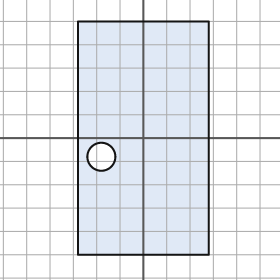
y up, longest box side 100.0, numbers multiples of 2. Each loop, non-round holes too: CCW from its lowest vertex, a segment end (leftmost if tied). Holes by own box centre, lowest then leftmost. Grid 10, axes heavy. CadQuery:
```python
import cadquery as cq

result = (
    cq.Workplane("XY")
    .moveTo(-28.0, -50.0)
    .lineTo(28.0, -50.0)
    .lineTo(28.0, 50.0)
    .lineTo(-28.0, 50.0)
    .close()
    .moveTo(-18.0, -8.0)
    .circle(6.0)
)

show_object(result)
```